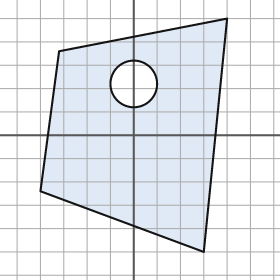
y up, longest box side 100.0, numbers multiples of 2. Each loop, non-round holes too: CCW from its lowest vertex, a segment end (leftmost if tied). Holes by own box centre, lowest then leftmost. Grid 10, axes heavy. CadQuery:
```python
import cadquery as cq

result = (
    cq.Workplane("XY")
    .moveTo(30.0, -50.0)
    .lineTo(40.0, 50.0)
    .lineTo(-32.0, 36.0)
    .lineTo(-40.0, -24.0)
    .close()
    .moveTo(0.0, 22.0)
    .circle(10.0)
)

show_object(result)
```